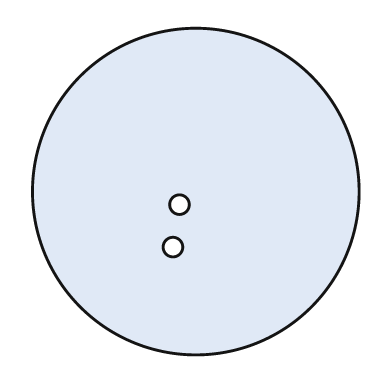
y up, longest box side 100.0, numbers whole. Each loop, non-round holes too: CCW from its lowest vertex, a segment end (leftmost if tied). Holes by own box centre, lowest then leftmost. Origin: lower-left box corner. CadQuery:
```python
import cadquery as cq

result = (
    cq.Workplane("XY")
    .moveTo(50.0, 50.0)
    .circle(50.0)
    .moveTo(43.0, 33.0)
    .circle(3.0)
    .moveTo(45.0, 46.0)
    .circle(3.0)
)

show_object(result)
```